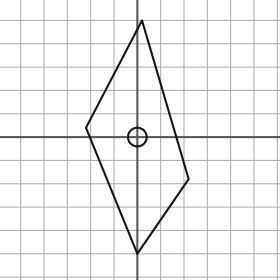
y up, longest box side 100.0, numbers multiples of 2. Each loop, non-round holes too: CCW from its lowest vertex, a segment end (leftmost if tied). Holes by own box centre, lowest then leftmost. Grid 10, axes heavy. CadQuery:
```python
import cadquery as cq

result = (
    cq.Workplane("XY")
    .moveTo(0.0, -50.0)
    .lineTo(22.0, -18.0)
    .lineTo(2.0, 50.0)
    .lineTo(-22.0, 4.0)
    .close()
    .moveTo(0.0, 0.0)
    .circle(4.0)
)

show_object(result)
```